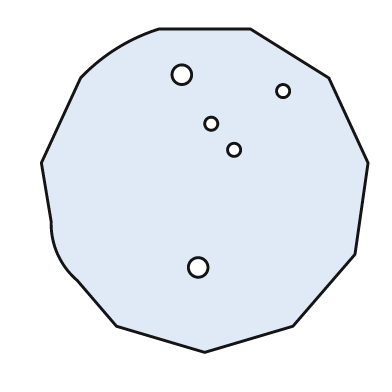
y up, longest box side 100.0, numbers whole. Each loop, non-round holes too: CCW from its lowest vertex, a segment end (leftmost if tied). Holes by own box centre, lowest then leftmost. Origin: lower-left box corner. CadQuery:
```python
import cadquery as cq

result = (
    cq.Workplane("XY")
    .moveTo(50.0, 0.0)
    .lineTo(77.0, 8.0)
    .lineTo(96.0, 30.0)
    .lineTo(100.0, 58.0)
    .lineTo(88.0, 84.0)
    .lineTo(64.0, 99.0)
    .lineTo(36.0, 99.0)
    .threePointArc((23.0, 93.0), (12.0, 84.0))
    .lineTo(0.0, 58.0)
    .lineTo(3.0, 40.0)
    .threePointArc((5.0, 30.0), (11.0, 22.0))
    .lineTo(23.0, 8.0)
    .close()
    .moveTo(48.0, 26.0)
    .circle(3.0)
    .moveTo(59.0, 62.0)
    .circle(2.0)
    .moveTo(52.0, 70.0)
    .circle(2.0)
    .moveTo(74.0, 80.0)
    .circle(2.0)
    .moveTo(43.0, 85.0)
    .circle(3.0)
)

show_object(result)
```